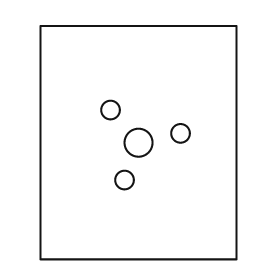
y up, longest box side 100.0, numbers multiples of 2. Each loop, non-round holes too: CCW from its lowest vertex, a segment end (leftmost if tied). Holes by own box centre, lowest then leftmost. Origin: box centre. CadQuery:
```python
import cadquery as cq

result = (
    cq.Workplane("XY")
    .moveTo(-42.0, -50.0)
    .lineTo(42.0, -50.0)
    .lineTo(42.0, 50.0)
    .lineTo(-42.0, 50.0)
    .close()
    .moveTo(-6.0, -16.0)
    .circle(4.0)
    .moveTo(0.0, 0.0)
    .circle(6.0)
    .moveTo(18.0, 4.0)
    .circle(4.0)
    .moveTo(-12.0, 14.0)
    .circle(4.0)
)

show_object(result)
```